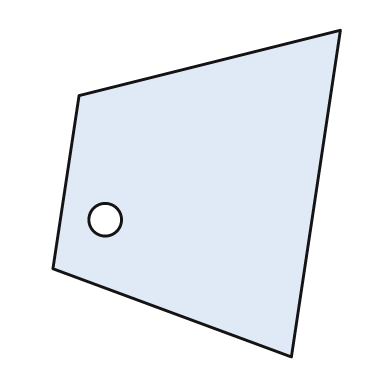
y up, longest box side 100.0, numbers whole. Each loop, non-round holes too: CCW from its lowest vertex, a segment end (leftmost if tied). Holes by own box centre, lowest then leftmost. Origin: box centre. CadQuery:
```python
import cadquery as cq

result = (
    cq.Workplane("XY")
    .moveTo(29.0, -50.0)
    .lineTo(44.0, 50.0)
    .lineTo(-36.0, 30.0)
    .lineTo(-44.0, -23.0)
    .close()
    .moveTo(-28.0, -8.0)
    .circle(5.0)
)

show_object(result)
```